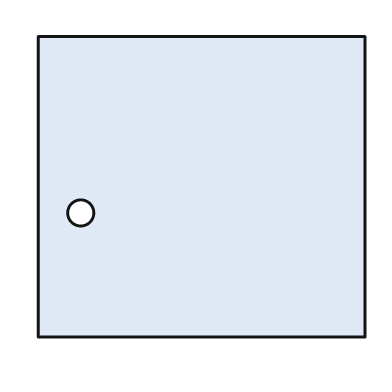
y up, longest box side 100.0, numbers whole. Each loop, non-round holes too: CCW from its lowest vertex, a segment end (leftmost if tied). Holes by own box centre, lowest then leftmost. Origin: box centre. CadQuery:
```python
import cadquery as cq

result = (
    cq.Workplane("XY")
    .moveTo(-50.0, -46.0)
    .lineTo(50.0, -46.0)
    .lineTo(50.0, 46.0)
    .lineTo(-50.0, 46.0)
    .close()
    .moveTo(-37.0, -8.0)
    .circle(4.0)
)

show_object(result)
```